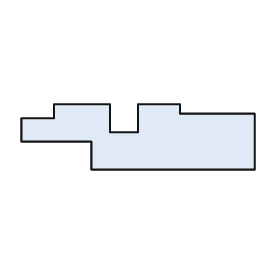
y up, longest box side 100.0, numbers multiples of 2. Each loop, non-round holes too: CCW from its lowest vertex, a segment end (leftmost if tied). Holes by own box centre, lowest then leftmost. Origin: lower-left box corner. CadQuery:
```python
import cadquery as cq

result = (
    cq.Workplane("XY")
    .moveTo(30.0, 0.0)
    .lineTo(100.0, 0.0)
    .lineTo(100.0, 24.0)
    .lineTo(68.0, 24.0)
    .lineTo(68.0, 28.0)
    .lineTo(50.0, 28.0)
    .lineTo(50.0, 16.0)
    .lineTo(38.0, 16.0)
    .lineTo(38.0, 28.0)
    .lineTo(14.0, 28.0)
    .lineTo(14.0, 22.0)
    .lineTo(0.0, 22.0)
    .lineTo(0.0, 12.0)
    .lineTo(30.0, 12.0)
    .close()
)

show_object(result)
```